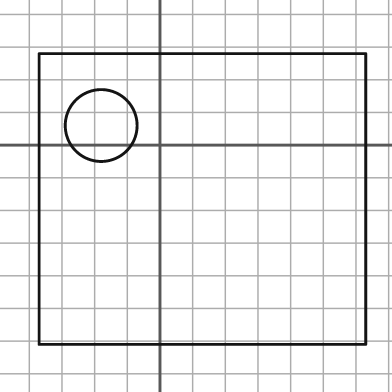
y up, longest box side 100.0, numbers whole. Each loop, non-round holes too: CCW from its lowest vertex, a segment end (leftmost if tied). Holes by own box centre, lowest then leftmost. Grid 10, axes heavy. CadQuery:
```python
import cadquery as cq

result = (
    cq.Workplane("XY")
    .moveTo(-37.0, -61.0)
    .lineTo(63.0, -61.0)
    .lineTo(63.0, 28.0)
    .lineTo(-37.0, 28.0)
    .close()
    .moveTo(-18.0, 6.0)
    .circle(11.0)
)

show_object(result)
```